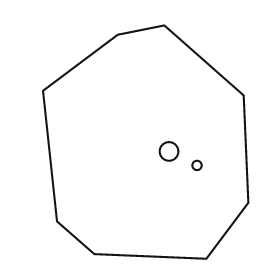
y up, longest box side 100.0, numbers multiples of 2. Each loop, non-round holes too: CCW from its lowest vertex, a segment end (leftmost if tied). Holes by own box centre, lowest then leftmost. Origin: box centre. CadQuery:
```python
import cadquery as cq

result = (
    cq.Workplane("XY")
    .moveTo(26.0, -50.0)
    .lineTo(44.0, -26.0)
    .lineTo(42.0, 20.0)
    .lineTo(8.0, 50.0)
    .lineTo(-12.0, 46.0)
    .lineTo(-44.0, 22.0)
    .lineTo(-38.0, -34.0)
    .lineTo(-22.0, -48.0)
    .close()
    .moveTo(22.0, -10.0)
    .circle(2.0)
    .moveTo(10.0, -4.0)
    .circle(4.0)
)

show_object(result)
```